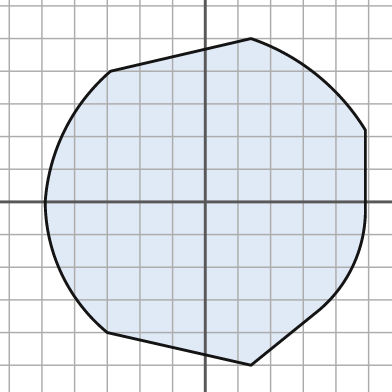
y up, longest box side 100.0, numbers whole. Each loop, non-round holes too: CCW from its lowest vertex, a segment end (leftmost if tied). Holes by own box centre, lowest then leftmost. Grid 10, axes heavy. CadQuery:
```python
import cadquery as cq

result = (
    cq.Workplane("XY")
    .moveTo(14.0, -50.0)
    .lineTo(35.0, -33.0)
    .threePointArc((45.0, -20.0), (49.0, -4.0))
    .lineTo(49.0, 22.0)
    .threePointArc((34.0, 39.0), (14.0, 50.0))
    .lineTo(-29.0, 40.0)
    .threePointArc((-43.0, 22.0), (-49.0, 0.0))
    .threePointArc((-44.0, -22.0), (-30.0, -40.0))
    .close()
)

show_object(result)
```